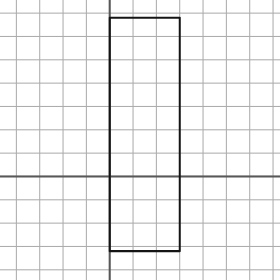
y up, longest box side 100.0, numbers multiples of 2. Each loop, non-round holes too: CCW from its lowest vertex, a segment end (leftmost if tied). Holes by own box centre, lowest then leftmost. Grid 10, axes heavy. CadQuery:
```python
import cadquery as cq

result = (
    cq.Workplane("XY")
    .moveTo(0.0, -32.0)
    .lineTo(30.0, -32.0)
    .lineTo(30.0, 68.0)
    .lineTo(0.0, 68.0)
    .close()
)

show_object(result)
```